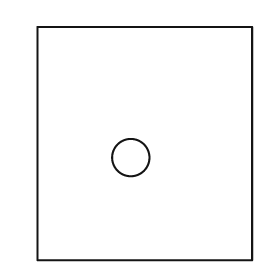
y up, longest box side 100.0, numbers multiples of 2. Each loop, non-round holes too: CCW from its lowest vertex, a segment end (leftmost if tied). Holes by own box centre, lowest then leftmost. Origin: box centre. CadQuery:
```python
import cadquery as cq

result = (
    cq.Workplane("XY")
    .moveTo(-46.0, -50.0)
    .lineTo(46.0, -50.0)
    .lineTo(46.0, 50.0)
    .lineTo(-46.0, 50.0)
    .close()
    .moveTo(-6.0, -6.0)
    .circle(8.0)
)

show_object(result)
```